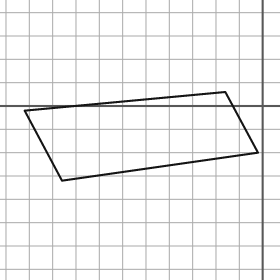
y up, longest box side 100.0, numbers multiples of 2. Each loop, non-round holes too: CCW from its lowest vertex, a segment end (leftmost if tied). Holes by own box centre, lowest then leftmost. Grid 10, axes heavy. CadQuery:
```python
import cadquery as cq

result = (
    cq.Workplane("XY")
    .moveTo(-86.0, -32.0)
    .lineTo(-2.0, -20.0)
    .lineTo(-16.0, 6.0)
    .lineTo(-102.0, -2.0)
    .close()
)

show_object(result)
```